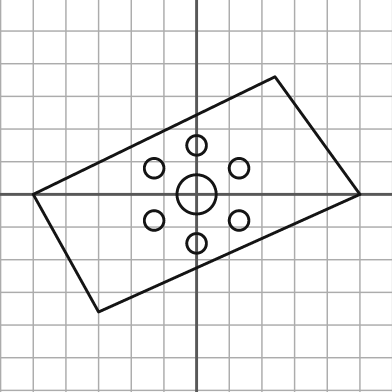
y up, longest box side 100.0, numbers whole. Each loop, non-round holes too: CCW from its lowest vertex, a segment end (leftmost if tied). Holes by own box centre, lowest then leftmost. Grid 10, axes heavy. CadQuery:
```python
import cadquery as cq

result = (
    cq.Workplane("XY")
    .moveTo(-30.0, -36.0)
    .lineTo(50.0, 0.0)
    .lineTo(24.0, 36.0)
    .lineTo(-50.0, 0.0)
    .close()
    .moveTo(0.0, -15.0)
    .circle(3.0)
    .moveTo(-13.0, -8.0)
    .circle(3.0)
    .moveTo(13.0, -8.0)
    .circle(3.0)
    .moveTo(0.0, 0.0)
    .circle(6.0)
    .moveTo(-13.0, 8.0)
    .circle(3.0)
    .moveTo(13.0, 8.0)
    .circle(3.0)
    .moveTo(0.0, 15.0)
    .circle(3.0)
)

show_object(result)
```